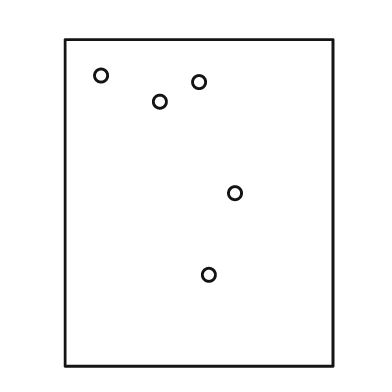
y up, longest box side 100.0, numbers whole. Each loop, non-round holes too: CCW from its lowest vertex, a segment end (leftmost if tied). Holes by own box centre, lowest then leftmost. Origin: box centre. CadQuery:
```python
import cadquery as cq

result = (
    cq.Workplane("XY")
    .moveTo(-41.0, -50.0)
    .lineTo(41.0, -50.0)
    .lineTo(41.0, 50.0)
    .lineTo(-41.0, 50.0)
    .close()
    .moveTo(3.0, -22.0)
    .circle(2.0)
    .moveTo(11.0, 3.0)
    .circle(2.0)
    .moveTo(-12.0, 31.0)
    .circle(2.0)
    .moveTo(0.0, 37.0)
    .circle(2.0)
    .moveTo(-30.0, 39.0)
    .circle(2.0)
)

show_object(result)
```